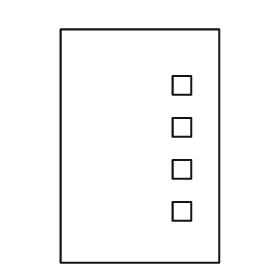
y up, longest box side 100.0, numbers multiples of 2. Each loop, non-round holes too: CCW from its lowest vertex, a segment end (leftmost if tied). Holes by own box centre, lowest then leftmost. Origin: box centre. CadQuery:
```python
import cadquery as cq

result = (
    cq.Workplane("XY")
    .moveTo(-34.0, -50.0)
    .lineTo(34.0, -50.0)
    .lineTo(34.0, 50.0)
    .lineTo(-34.0, 50.0)
    .close()
    .moveTo(14.0, -32.0)
    .lineTo(22.0, -32.0)
    .lineTo(22.0, -24.0)
    .lineTo(14.0, -24.0)
    .close()
    .moveTo(14.0, -14.0)
    .lineTo(22.0, -14.0)
    .lineTo(22.0, -6.0)
    .lineTo(14.0, -6.0)
    .close()
    .moveTo(14.0, 4.0)
    .lineTo(22.0, 4.0)
    .lineTo(22.0, 12.0)
    .lineTo(14.0, 12.0)
    .close()
    .moveTo(14.0, 22.0)
    .lineTo(22.0, 22.0)
    .lineTo(22.0, 30.0)
    .lineTo(14.0, 30.0)
    .close()
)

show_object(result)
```